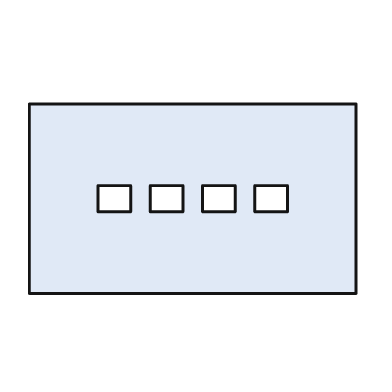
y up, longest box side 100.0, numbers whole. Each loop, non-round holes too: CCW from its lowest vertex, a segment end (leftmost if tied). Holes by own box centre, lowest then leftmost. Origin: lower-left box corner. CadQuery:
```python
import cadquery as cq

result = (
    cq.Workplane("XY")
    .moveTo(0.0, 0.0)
    .lineTo(100.0, 0.0)
    .lineTo(100.0, 58.0)
    .lineTo(0.0, 58.0)
    .close()
    .moveTo(21.0, 25.0)
    .lineTo(31.0, 25.0)
    .lineTo(31.0, 33.0)
    .lineTo(21.0, 33.0)
    .close()
    .moveTo(37.0, 25.0)
    .lineTo(47.0, 25.0)
    .lineTo(47.0, 33.0)
    .lineTo(37.0, 33.0)
    .close()
    .moveTo(53.0, 25.0)
    .lineTo(63.0, 25.0)
    .lineTo(63.0, 33.0)
    .lineTo(53.0, 33.0)
    .close()
    .moveTo(69.0, 25.0)
    .lineTo(79.0, 25.0)
    .lineTo(79.0, 33.0)
    .lineTo(69.0, 33.0)
    .close()
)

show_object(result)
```